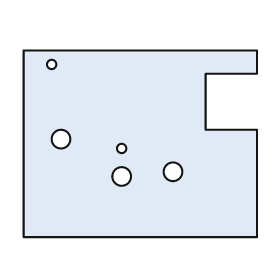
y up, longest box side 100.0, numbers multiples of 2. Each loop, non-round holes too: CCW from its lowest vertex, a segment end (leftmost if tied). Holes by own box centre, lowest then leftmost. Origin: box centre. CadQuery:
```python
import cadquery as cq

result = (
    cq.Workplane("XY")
    .moveTo(-50.0, -40.0)
    .lineTo(50.0, -40.0)
    .lineTo(50.0, 6.0)
    .lineTo(28.0, 6.0)
    .lineTo(28.0, 30.0)
    .lineTo(50.0, 30.0)
    .lineTo(50.0, 40.0)
    .lineTo(-50.0, 40.0)
    .close()
    .moveTo(-8.0, -14.0)
    .circle(4.0)
    .moveTo(14.0, -12.0)
    .circle(4.0)
    .moveTo(-8.0, -2.0)
    .circle(2.0)
    .moveTo(-34.0, 2.0)
    .circle(4.0)
    .moveTo(-38.0, 34.0)
    .circle(2.0)
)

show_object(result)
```